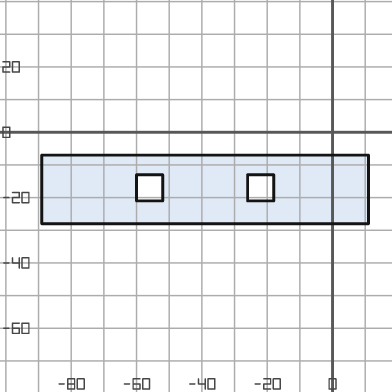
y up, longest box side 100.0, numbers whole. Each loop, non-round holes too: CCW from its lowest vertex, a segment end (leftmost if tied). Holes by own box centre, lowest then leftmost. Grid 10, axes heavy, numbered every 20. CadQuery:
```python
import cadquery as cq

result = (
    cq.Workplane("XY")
    .moveTo(-89.0, -28.0)
    .lineTo(11.0, -28.0)
    .lineTo(11.0, -7.0)
    .lineTo(-89.0, -7.0)
    .close()
    .moveTo(-60.0, -21.0)
    .lineTo(-52.0, -21.0)
    .lineTo(-52.0, -13.0)
    .lineTo(-60.0, -13.0)
    .close()
    .moveTo(-26.0, -21.0)
    .lineTo(-18.0, -21.0)
    .lineTo(-18.0, -13.0)
    .lineTo(-26.0, -13.0)
    .close()
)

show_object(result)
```